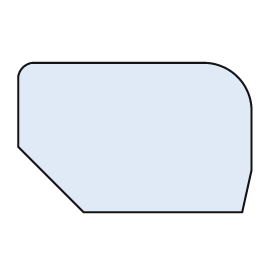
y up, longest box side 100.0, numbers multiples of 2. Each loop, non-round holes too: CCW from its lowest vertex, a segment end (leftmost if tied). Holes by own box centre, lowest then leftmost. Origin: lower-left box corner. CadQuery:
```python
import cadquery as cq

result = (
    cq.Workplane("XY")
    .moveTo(28.0, 0.0)
    .lineTo(96.0, 0.0)
    .lineTo(100.0, 18.0)
    .lineTo(100.0, 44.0)
    .threePointArc((94.0, 58.0), (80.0, 64.0))
    .lineTo(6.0, 64.0)
    .threePointArc((2.0, 62.0), (0.0, 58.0))
    .lineTo(0.0, 28.0)
    .close()
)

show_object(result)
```